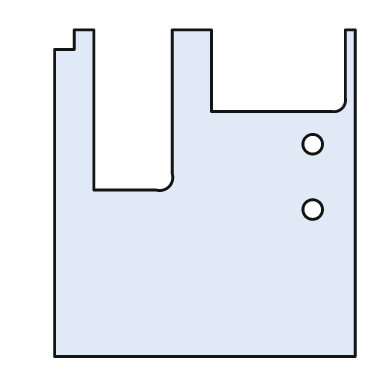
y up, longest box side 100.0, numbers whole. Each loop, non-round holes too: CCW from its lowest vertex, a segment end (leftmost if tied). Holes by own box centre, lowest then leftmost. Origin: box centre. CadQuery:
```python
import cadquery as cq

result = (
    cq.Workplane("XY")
    .moveTo(-46.0, -50.0)
    .lineTo(46.0, -50.0)
    .lineTo(46.0, 50.0)
    .lineTo(43.0, 50.0)
    .lineTo(43.0, 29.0)
    .threePointArc((42.0, 26.0), (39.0, 25.0))
    .lineTo(2.0, 25.0)
    .lineTo(2.0, 50.0)
    .lineTo(-10.0, 50.0)
    .lineTo(-10.0, 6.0)
    .threePointArc((-11.0, 2.0), (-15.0, 1.0))
    .lineTo(-34.0, 1.0)
    .lineTo(-34.0, 50.0)
    .lineTo(-40.0, 50.0)
    .lineTo(-40.0, 44.0)
    .lineTo(-46.0, 44.0)
    .close()
    .moveTo(33.0, -5.0)
    .circle(3.0)
    .moveTo(33.0, 15.0)
    .circle(3.0)
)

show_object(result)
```